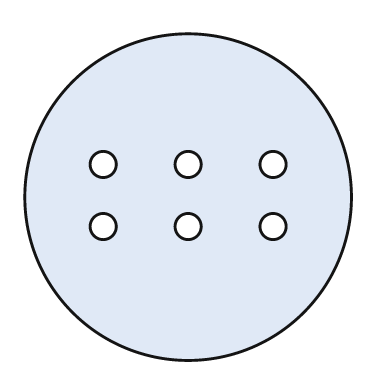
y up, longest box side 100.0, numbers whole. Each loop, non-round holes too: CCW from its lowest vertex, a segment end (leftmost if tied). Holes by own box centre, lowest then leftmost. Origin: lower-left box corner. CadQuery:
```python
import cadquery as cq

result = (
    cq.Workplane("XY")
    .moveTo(50.0, 50.0)
    .circle(50.0)
    .moveTo(24.0, 41.0)
    .circle(4.0)
    .moveTo(50.0, 41.0)
    .circle(4.0)
    .moveTo(76.0, 41.0)
    .circle(4.0)
    .moveTo(24.0, 60.0)
    .circle(4.0)
    .moveTo(50.0, 60.0)
    .circle(4.0)
    .moveTo(76.0, 60.0)
    .circle(4.0)
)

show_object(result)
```